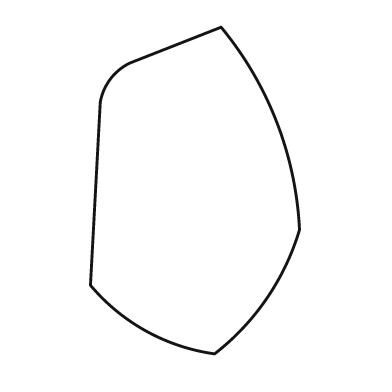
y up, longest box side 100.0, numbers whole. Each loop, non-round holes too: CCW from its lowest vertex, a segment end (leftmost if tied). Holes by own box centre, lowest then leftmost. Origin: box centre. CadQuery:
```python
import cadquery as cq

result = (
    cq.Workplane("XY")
    .moveTo(6.0, -50.0)
    .threePointArc((22.0, -33.0), (32.0, -12.0))
    .threePointArc((25.0, 21.0), (8.0, 50.0))
    .lineTo(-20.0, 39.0)
    .threePointArc((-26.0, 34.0), (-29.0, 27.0))
    .lineTo(-32.0, -29.0)
    .threePointArc((-15.0, -43.0), (6.0, -50.0))
    .close()
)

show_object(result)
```